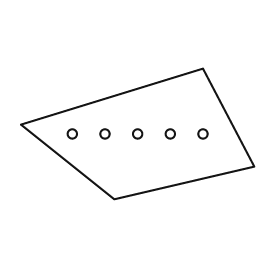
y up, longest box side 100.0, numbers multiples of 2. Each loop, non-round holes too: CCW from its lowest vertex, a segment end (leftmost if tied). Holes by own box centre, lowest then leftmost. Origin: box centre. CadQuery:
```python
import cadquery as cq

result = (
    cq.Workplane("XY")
    .moveTo(-10.0, -28.0)
    .lineTo(50.0, -14.0)
    .lineTo(28.0, 28.0)
    .lineTo(-50.0, 4.0)
    .close()
    .moveTo(-28.0, 0.0)
    .circle(2.0)
    .moveTo(-14.0, 0.0)
    .circle(2.0)
    .moveTo(0.0, 0.0)
    .circle(2.0)
    .moveTo(14.0, 0.0)
    .circle(2.0)
    .moveTo(28.0, 0.0)
    .circle(2.0)
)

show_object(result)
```